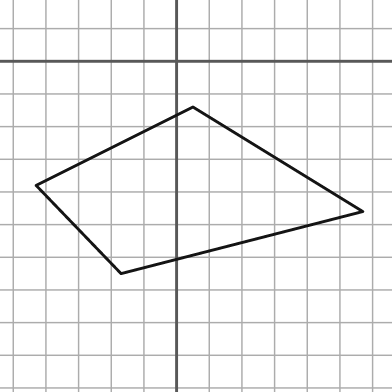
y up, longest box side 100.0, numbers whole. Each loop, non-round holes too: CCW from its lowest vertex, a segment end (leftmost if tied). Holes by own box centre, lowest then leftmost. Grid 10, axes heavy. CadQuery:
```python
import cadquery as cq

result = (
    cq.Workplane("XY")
    .moveTo(-17.0, -65.0)
    .lineTo(57.0, -46.0)
    .lineTo(5.0, -14.0)
    .lineTo(-43.0, -38.0)
    .close()
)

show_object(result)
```